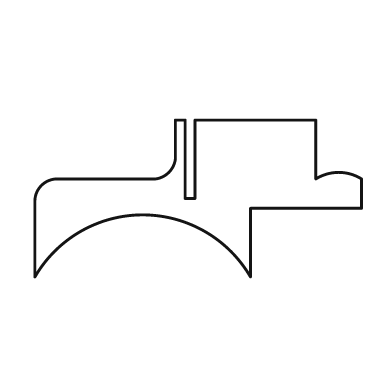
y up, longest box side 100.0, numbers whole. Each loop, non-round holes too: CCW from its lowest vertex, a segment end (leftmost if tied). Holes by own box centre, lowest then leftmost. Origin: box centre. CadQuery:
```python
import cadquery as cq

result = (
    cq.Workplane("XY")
    .moveTo(-50.0, -24.0)
    .threePointArc((-17.0, -5.0), (16.0, -24.0))
    .lineTo(16.0, -3.0)
    .lineTo(50.0, -3.0)
    .lineTo(50.0, 6.0)
    .threePointArc((43.0, 8.0), (36.0, 6.0))
    .lineTo(36.0, 24.0)
    .lineTo(-1.0, 24.0)
    .lineTo(-1.0, 0.0)
    .lineTo(-4.0, 0.0)
    .lineTo(-4.0, 24.0)
    .lineTo(-7.0, 24.0)
    .lineTo(-7.0, 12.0)
    .threePointArc((-9.0, 8.0), (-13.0, 6.0))
    .lineTo(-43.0, 6.0)
    .threePointArc((-48.0, 4.0), (-50.0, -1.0))
    .close()
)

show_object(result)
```